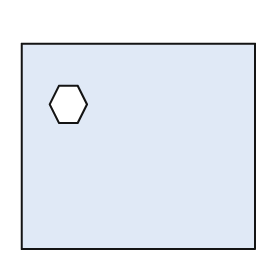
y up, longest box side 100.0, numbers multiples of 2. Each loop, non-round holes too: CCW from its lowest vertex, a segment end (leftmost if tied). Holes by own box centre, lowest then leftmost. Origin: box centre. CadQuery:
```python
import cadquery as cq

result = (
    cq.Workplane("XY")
    .moveTo(-50.0, -44.0)
    .lineTo(50.0, -44.0)
    .lineTo(50.0, 44.0)
    .lineTo(-50.0, 44.0)
    .close()
    .moveTo(-34.0, 10.0)
    .lineTo(-26.0, 10.0)
    .lineTo(-22.0, 18.0)
    .lineTo(-26.0, 26.0)
    .lineTo(-34.0, 26.0)
    .lineTo(-38.0, 18.0)
    .close()
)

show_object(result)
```